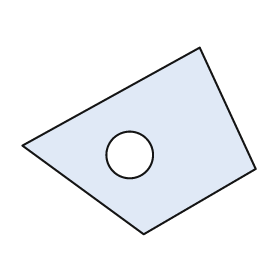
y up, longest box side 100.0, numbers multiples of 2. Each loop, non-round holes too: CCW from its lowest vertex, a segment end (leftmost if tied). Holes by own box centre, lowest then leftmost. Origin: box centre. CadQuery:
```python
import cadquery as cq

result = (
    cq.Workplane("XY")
    .moveTo(2.0, -40.0)
    .lineTo(50.0, -12.0)
    .lineTo(26.0, 40.0)
    .lineTo(-50.0, -2.0)
    .close()
    .moveTo(-4.0, -6.0)
    .circle(10.0)
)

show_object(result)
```